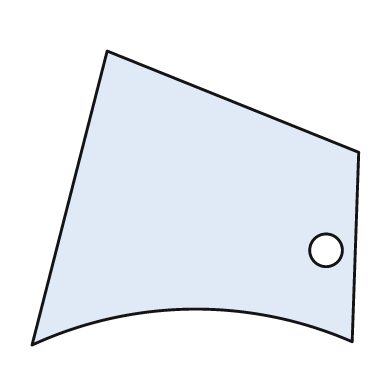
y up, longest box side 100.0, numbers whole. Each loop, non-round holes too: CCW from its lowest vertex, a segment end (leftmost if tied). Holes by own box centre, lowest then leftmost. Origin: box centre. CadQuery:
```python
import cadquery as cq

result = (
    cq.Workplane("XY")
    .moveTo(-50.0, -45.0)
    .threePointArc((-1.0, -34.0), (48.0, -44.0))
    .lineTo(50.0, 14.0)
    .lineTo(-27.0, 45.0)
    .close()
    .moveTo(40.0, -16.0)
    .circle(5.0)
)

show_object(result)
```